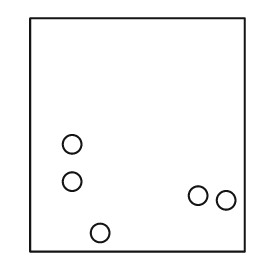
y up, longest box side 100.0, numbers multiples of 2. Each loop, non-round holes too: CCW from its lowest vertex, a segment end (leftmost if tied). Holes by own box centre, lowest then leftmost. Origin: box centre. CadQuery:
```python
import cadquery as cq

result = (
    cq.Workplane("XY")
    .moveTo(-46.0, -50.0)
    .lineTo(46.0, -50.0)
    .lineTo(46.0, 50.0)
    .lineTo(-46.0, 50.0)
    .close()
    .moveTo(-16.0, -42.0)
    .circle(4.0)
    .moveTo(38.0, -28.0)
    .circle(4.0)
    .moveTo(26.0, -26.0)
    .circle(4.0)
    .moveTo(-28.0, -20.0)
    .circle(4.0)
    .moveTo(-28.0, -4.0)
    .circle(4.0)
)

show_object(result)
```